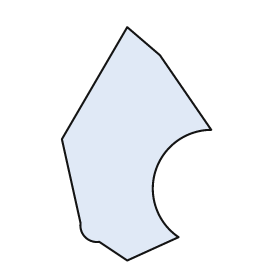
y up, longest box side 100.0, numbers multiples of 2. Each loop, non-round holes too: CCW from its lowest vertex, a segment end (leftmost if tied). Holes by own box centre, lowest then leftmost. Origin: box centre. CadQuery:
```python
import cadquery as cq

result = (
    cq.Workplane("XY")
    .moveTo(-4.0, -50.0)
    .lineTo(18.0, -40.0)
    .threePointArc((8.0, -12.0), (32.0, 6.0))
    .lineTo(10.0, 38.0)
    .lineTo(-4.0, 50.0)
    .lineTo(-32.0, 2.0)
    .lineTo(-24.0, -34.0)
    .threePointArc((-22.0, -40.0), (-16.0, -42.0))
    .close()
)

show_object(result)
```